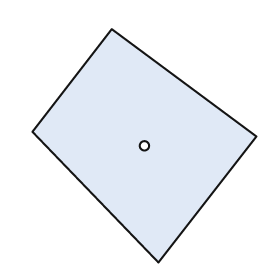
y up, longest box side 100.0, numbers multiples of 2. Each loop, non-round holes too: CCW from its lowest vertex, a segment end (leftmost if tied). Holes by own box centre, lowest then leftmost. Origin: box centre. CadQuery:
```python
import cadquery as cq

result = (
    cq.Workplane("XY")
    .moveTo(6.0, -50.0)
    .lineTo(48.0, 4.0)
    .lineTo(-14.0, 50.0)
    .lineTo(-48.0, 6.0)
    .close()
    .moveTo(0.0, 0.0)
    .circle(2.0)
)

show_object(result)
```